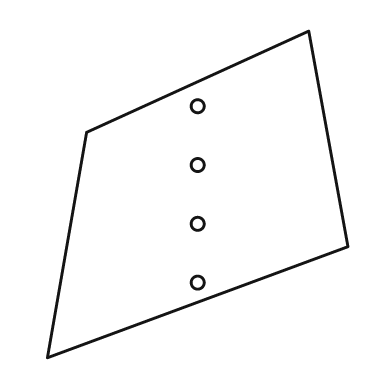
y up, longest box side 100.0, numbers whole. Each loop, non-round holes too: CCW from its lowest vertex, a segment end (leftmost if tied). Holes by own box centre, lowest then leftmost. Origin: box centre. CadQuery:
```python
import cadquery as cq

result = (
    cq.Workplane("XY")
    .moveTo(-46.0, -50.0)
    .lineTo(46.0, -16.0)
    .lineTo(34.0, 50.0)
    .lineTo(-34.0, 19.0)
    .close()
    .moveTo(0.0, -27.0)
    .circle(2.0)
    .moveTo(0.0, -9.0)
    .circle(2.0)
    .moveTo(0.0, 9.0)
    .circle(2.0)
    .moveTo(0.0, 27.0)
    .circle(2.0)
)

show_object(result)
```